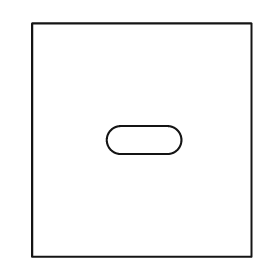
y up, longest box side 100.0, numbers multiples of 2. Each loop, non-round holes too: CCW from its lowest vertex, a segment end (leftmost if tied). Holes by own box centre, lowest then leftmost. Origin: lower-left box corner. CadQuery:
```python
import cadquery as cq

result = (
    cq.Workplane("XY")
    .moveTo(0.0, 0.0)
    .lineTo(94.0, 0.0)
    .lineTo(94.0, 100.0)
    .lineTo(0.0, 100.0)
    .close()
    .moveTo(38.0, 44.0)
    .lineTo(58.0, 44.0)
    .threePointArc((64.0, 50.0), (58.0, 56.0))
    .lineTo(38.0, 56.0)
    .threePointArc((32.0, 50.0), (38.0, 44.0))
    .close()
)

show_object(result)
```